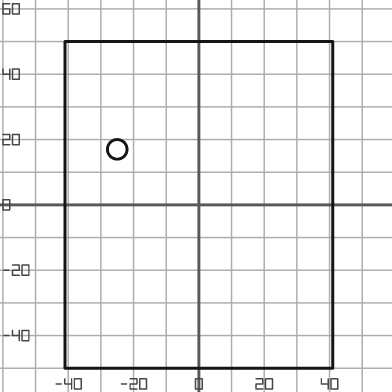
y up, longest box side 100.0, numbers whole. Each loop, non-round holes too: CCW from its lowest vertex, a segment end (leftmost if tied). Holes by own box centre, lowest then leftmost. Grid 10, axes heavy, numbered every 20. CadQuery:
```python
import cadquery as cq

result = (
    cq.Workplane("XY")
    .moveTo(-41.0, -50.0)
    .lineTo(41.0, -50.0)
    .lineTo(41.0, 50.0)
    .lineTo(-41.0, 50.0)
    .close()
    .moveTo(-25.0, 17.0)
    .circle(3.0)
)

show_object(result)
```